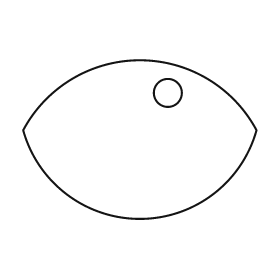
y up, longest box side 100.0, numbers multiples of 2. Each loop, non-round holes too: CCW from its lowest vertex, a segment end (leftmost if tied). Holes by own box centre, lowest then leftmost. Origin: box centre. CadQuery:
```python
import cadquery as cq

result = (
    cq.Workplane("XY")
    .moveTo(-50.0, 4.0)
    .threePointArc((0.0, -34.0), (50.0, 4.0))
    .threePointArc((0.0, 34.0), (-50.0, 4.0))
    .close()
    .moveTo(12.0, 20.0)
    .circle(6.0)
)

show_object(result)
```